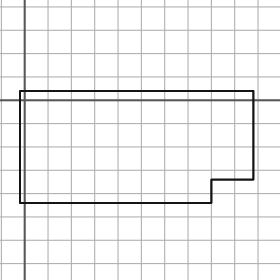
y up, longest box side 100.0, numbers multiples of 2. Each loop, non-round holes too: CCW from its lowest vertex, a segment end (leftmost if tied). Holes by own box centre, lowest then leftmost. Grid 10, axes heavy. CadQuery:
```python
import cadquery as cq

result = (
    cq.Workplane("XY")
    .moveTo(-2.0, -44.0)
    .lineTo(80.0, -44.0)
    .lineTo(80.0, -34.0)
    .lineTo(98.0, -34.0)
    .lineTo(98.0, 4.0)
    .lineTo(-2.0, 4.0)
    .close()
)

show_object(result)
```